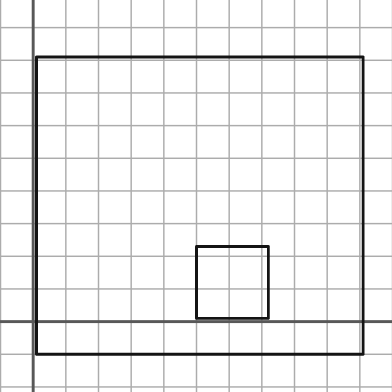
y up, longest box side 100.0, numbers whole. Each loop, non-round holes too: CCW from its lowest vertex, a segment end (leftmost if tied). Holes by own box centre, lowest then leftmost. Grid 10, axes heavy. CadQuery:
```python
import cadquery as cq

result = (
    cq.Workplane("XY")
    .moveTo(1.0, -10.0)
    .lineTo(101.0, -10.0)
    .lineTo(101.0, 81.0)
    .lineTo(1.0, 81.0)
    .close()
    .moveTo(50.0, 1.0)
    .lineTo(72.0, 1.0)
    .lineTo(72.0, 23.0)
    .lineTo(50.0, 23.0)
    .close()
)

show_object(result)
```